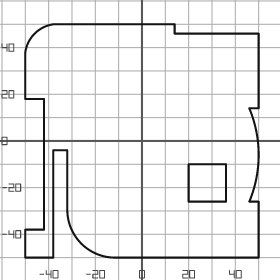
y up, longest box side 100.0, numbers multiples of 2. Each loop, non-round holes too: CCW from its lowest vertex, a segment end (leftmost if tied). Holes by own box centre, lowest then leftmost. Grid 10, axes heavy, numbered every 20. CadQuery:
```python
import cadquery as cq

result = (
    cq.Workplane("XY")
    .moveTo(-50.0, -50.0)
    .lineTo(-38.0, -50.0)
    .lineTo(-38.0, -4.0)
    .lineTo(-32.0, -4.0)
    .lineTo(-32.0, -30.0)
    .threePointArc((-26.0, -44.0), (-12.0, -50.0))
    .lineTo(50.0, -50.0)
    .lineTo(50.0, -26.0)
    .lineTo(46.0, -26.0)
    .threePointArc((50.0, -6.0), (46.0, 14.0))
    .lineTo(50.0, 14.0)
    .lineTo(50.0, 46.0)
    .lineTo(14.0, 46.0)
    .lineTo(14.0, 50.0)
    .lineTo(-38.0, 50.0)
    .threePointArc((-46.0, 46.0), (-50.0, 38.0))
    .lineTo(-50.0, 18.0)
    .lineTo(-42.0, 18.0)
    .lineTo(-42.0, -38.0)
    .lineTo(-50.0, -38.0)
    .close()
    .moveTo(20.0, -26.0)
    .lineTo(36.0, -26.0)
    .lineTo(36.0, -10.0)
    .lineTo(20.0, -10.0)
    .close()
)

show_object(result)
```